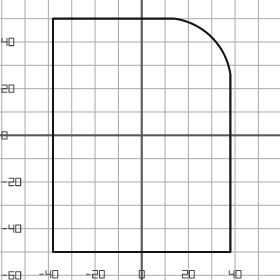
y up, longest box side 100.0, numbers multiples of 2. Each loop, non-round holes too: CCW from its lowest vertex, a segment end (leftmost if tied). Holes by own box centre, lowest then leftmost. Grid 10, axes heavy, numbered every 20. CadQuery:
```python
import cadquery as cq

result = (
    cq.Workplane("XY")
    .moveTo(-38.0, -50.0)
    .lineTo(38.0, -50.0)
    .lineTo(38.0, 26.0)
    .threePointArc((30.0, 42.0), (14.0, 50.0))
    .lineTo(-38.0, 50.0)
    .close()
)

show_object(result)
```